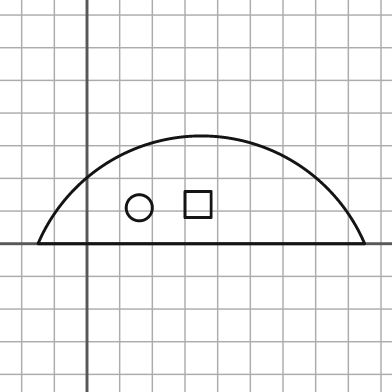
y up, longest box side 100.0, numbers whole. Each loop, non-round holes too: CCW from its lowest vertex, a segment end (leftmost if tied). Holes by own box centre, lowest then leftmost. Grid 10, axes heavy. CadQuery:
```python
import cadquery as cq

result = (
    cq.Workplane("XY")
    .moveTo(-15.0, 0.0)
    .lineTo(85.0, 0.0)
    .threePointArc((35.0, 33.0), (-15.0, 0.0))
    .close()
    .moveTo(16.0, 11.0)
    .circle(4.0)
    .moveTo(30.0, 8.0)
    .lineTo(38.0, 8.0)
    .lineTo(38.0, 16.0)
    .lineTo(30.0, 16.0)
    .close()
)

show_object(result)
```